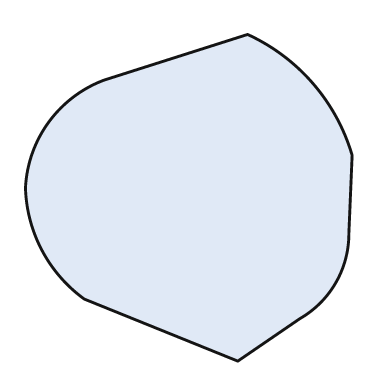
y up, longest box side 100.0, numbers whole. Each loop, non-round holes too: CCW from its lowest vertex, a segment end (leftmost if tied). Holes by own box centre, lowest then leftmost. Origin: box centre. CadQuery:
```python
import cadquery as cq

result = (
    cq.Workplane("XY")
    .moveTo(15.0, -50.0)
    .lineTo(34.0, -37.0)
    .threePointArc((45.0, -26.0), (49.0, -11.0))
    .lineTo(50.0, 13.0)
    .threePointArc((38.0, 35.0), (18.0, 50.0))
    .lineTo(-26.0, 36.0)
    .threePointArc((-43.0, 23.0), (-50.0, 3.0))
    .threePointArc((-45.0, -16.0), (-32.0, -31.0))
    .close()
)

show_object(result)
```